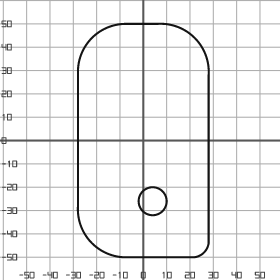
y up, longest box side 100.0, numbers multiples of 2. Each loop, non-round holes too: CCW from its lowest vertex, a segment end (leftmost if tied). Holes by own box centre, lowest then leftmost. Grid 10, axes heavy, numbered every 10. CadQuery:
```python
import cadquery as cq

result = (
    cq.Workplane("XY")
    .moveTo(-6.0, -50.0)
    .lineTo(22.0, -50.0)
    .threePointArc((26.0, -48.0), (28.0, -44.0))
    .lineTo(28.0, 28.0)
    .threePointArc((22.0, 44.0), (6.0, 50.0))
    .lineTo(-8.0, 50.0)
    .threePointArc((-22.0, 44.0), (-28.0, 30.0))
    .lineTo(-28.0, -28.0)
    .threePointArc((-22.0, -44.0), (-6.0, -50.0))
    .close()
    .moveTo(4.0, -26.0)
    .circle(6.0)
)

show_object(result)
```